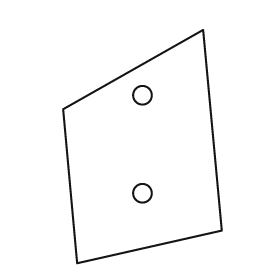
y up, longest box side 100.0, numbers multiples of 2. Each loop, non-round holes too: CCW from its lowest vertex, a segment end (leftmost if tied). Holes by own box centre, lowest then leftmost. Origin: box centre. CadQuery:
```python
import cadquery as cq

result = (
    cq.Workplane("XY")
    .moveTo(-28.0, -50.0)
    .lineTo(34.0, -36.0)
    .lineTo(26.0, 50.0)
    .lineTo(-34.0, 16.0)
    .close()
    .moveTo(0.0, -20.0)
    .circle(4.0)
    .moveTo(0.0, 22.0)
    .circle(4.0)
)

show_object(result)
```